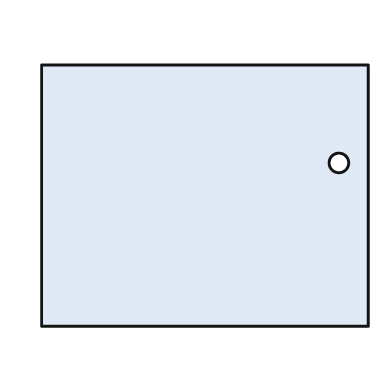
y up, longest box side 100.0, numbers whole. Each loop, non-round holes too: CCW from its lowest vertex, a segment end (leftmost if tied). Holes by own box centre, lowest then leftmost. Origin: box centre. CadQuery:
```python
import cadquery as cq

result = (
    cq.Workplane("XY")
    .moveTo(-50.0, -40.0)
    .lineTo(50.0, -40.0)
    .lineTo(50.0, 40.0)
    .lineTo(-50.0, 40.0)
    .close()
    .moveTo(41.0, 10.0)
    .circle(3.0)
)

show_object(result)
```